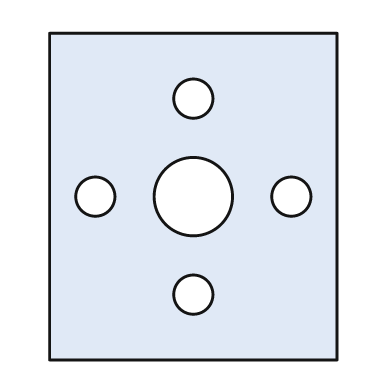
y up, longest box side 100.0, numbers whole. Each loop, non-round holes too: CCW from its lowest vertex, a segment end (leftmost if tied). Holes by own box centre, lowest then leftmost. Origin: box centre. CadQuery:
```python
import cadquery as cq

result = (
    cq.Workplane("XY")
    .moveTo(-44.0, -50.0)
    .lineTo(44.0, -50.0)
    .lineTo(44.0, 50.0)
    .lineTo(-44.0, 50.0)
    .close()
    .moveTo(0.0, -30.0)
    .circle(6.0)
    .moveTo(-30.0, 0.0)
    .circle(6.0)
    .moveTo(0.0, 0.0)
    .circle(12.0)
    .moveTo(30.0, 0.0)
    .circle(6.0)
    .moveTo(0.0, 30.0)
    .circle(6.0)
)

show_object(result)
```